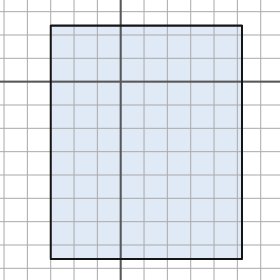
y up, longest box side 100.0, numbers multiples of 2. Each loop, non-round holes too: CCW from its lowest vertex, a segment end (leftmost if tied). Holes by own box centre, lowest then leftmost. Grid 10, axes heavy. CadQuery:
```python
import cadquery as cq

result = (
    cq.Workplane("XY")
    .moveTo(-30.0, -76.0)
    .lineTo(52.0, -76.0)
    .lineTo(52.0, 24.0)
    .lineTo(-30.0, 24.0)
    .close()
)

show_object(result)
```